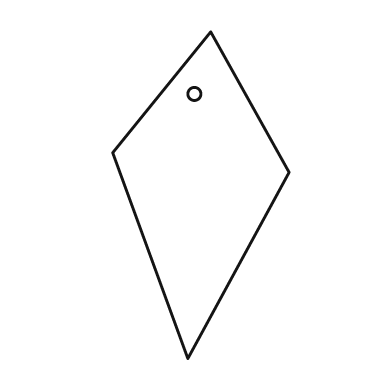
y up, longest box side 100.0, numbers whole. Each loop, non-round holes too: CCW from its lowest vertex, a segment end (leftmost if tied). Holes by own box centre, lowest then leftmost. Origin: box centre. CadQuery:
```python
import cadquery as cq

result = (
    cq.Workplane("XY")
    .moveTo(-4.0, -50.0)
    .lineTo(27.0, 7.0)
    .lineTo(3.0, 50.0)
    .lineTo(-27.0, 13.0)
    .close()
    .moveTo(-2.0, 31.0)
    .circle(2.0)
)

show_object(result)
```